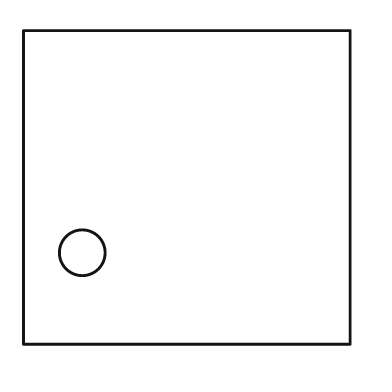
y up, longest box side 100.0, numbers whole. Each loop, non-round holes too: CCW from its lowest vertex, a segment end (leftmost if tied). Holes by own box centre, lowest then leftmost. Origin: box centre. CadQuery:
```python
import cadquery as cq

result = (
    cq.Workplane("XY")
    .moveTo(-50.0, -48.0)
    .lineTo(50.0, -48.0)
    .lineTo(50.0, 48.0)
    .lineTo(-50.0, 48.0)
    .close()
    .moveTo(-32.0, -20.0)
    .circle(7.0)
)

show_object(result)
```